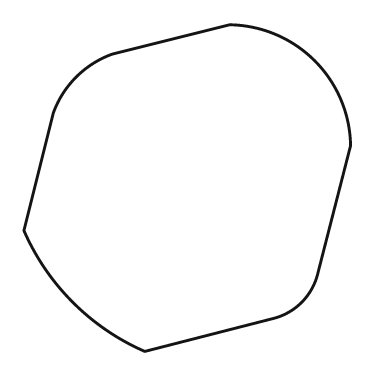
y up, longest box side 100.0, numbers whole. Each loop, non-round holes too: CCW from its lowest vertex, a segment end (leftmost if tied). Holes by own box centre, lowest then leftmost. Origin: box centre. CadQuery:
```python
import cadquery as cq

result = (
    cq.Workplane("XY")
    .moveTo(-13.0, -50.0)
    .lineTo(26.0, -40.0)
    .threePointArc((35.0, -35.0), (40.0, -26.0))
    .lineTo(50.0, 13.0)
    .threePointArc((39.0, 39.0), (13.0, 50.0))
    .lineTo(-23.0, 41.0)
    .threePointArc((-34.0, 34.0), (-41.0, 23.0))
    .lineTo(-50.0, -13.0)
    .threePointArc((-35.0, -35.0), (-13.0, -50.0))
    .close()
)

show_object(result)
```